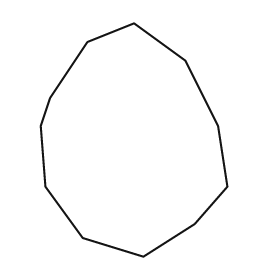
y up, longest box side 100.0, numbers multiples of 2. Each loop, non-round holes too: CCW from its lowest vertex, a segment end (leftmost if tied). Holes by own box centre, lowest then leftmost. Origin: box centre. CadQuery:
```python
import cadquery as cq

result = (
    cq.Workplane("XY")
    .moveTo(4.0, -50.0)
    .lineTo(26.0, -36.0)
    .lineTo(40.0, -20.0)
    .lineTo(36.0, 6.0)
    .lineTo(22.0, 34.0)
    .lineTo(0.0, 50.0)
    .lineTo(-20.0, 42.0)
    .lineTo(-36.0, 18.0)
    .lineTo(-40.0, 6.0)
    .lineTo(-38.0, -20.0)
    .lineTo(-22.0, -42.0)
    .close()
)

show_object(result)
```